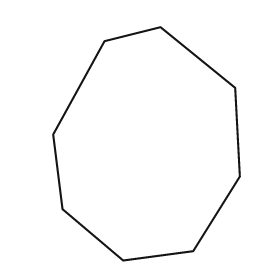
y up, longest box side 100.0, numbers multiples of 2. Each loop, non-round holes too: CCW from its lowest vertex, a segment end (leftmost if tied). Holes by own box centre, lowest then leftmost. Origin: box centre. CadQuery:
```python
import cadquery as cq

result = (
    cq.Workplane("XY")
    .moveTo(-10.0, -50.0)
    .lineTo(20.0, -46.0)
    .lineTo(40.0, -14.0)
    .lineTo(38.0, 24.0)
    .lineTo(6.0, 50.0)
    .lineTo(-18.0, 44.0)
    .lineTo(-40.0, 4.0)
    .lineTo(-36.0, -28.0)
    .close()
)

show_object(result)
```